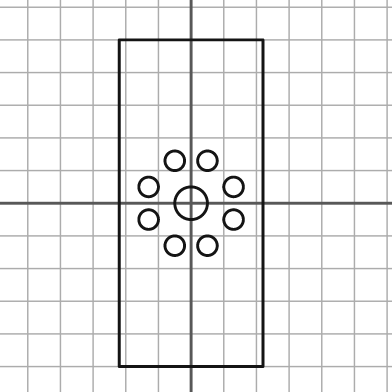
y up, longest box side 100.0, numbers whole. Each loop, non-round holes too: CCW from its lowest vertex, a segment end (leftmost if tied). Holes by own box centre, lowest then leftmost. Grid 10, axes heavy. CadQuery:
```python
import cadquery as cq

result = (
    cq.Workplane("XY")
    .moveTo(-22.0, -50.0)
    .lineTo(22.0, -50.0)
    .lineTo(22.0, 50.0)
    .lineTo(-22.0, 50.0)
    .close()
    .moveTo(-5.0, -13.0)
    .circle(3.0)
    .moveTo(5.0, -13.0)
    .circle(3.0)
    .moveTo(-13.0, -5.0)
    .circle(3.0)
    .moveTo(13.0, -5.0)
    .circle(3.0)
    .moveTo(0.0, 0.0)
    .circle(5.0)
    .moveTo(-13.0, 5.0)
    .circle(3.0)
    .moveTo(13.0, 5.0)
    .circle(3.0)
    .moveTo(-5.0, 13.0)
    .circle(3.0)
    .moveTo(5.0, 13.0)
    .circle(3.0)
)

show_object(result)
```